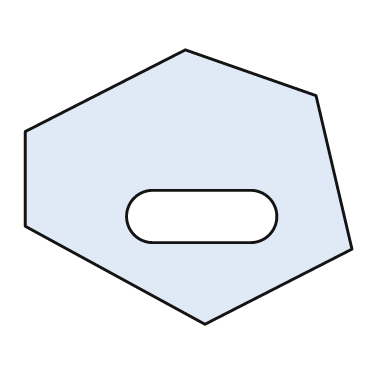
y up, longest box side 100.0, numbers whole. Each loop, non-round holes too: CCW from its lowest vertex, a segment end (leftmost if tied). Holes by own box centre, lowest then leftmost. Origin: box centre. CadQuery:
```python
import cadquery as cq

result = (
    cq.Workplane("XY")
    .moveTo(5.0, -42.0)
    .lineTo(50.0, -19.0)
    .lineTo(39.0, 28.0)
    .lineTo(-1.0, 42.0)
    .lineTo(-50.0, 17.0)
    .lineTo(-50.0, -12.0)
    .close()
    .moveTo(-11.0, -17.0)
    .lineTo(19.0, -17.0)
    .threePointArc((27.0, -9.0), (19.0, -1.0))
    .lineTo(-11.0, -1.0)
    .threePointArc((-19.0, -9.0), (-11.0, -17.0))
    .close()
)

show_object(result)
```